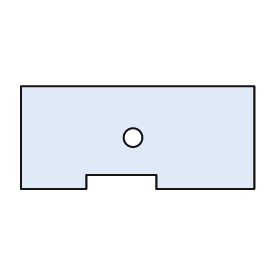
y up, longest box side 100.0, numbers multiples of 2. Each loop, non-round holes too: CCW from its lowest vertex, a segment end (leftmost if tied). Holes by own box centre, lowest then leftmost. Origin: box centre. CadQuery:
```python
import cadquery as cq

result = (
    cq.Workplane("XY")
    .moveTo(-50.0, -22.0)
    .lineTo(-22.0, -22.0)
    .lineTo(-22.0, -16.0)
    .lineTo(8.0, -16.0)
    .lineTo(8.0, -22.0)
    .lineTo(50.0, -22.0)
    .lineTo(50.0, 22.0)
    .lineTo(-50.0, 22.0)
    .close()
    .moveTo(-2.0, 0.0)
    .circle(4.0)
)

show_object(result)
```